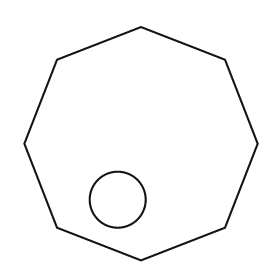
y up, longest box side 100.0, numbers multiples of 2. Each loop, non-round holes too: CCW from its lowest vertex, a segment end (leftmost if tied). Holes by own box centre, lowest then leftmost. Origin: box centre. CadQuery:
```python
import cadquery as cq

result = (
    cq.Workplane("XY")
    .moveTo(0.0, -50.0)
    .lineTo(36.0, -36.0)
    .lineTo(50.0, 0.0)
    .lineTo(36.0, 36.0)
    .lineTo(0.0, 50.0)
    .lineTo(-36.0, 36.0)
    .lineTo(-50.0, 0.0)
    .lineTo(-36.0, -36.0)
    .close()
    .moveTo(-10.0, -24.0)
    .circle(12.0)
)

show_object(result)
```